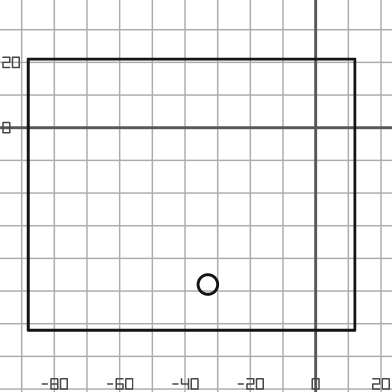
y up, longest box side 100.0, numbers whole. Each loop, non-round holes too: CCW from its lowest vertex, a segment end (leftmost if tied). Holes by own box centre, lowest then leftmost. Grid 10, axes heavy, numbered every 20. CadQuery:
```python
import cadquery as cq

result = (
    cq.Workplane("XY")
    .moveTo(-88.0, -62.0)
    .lineTo(12.0, -62.0)
    .lineTo(12.0, 21.0)
    .lineTo(-88.0, 21.0)
    .close()
    .moveTo(-33.0, -48.0)
    .circle(3.0)
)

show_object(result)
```